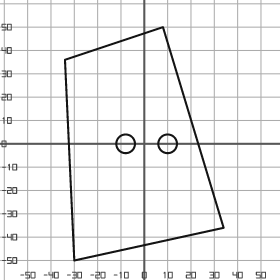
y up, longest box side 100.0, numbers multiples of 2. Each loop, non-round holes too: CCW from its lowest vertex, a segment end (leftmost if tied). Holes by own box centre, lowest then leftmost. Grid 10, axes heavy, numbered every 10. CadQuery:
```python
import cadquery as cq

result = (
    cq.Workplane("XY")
    .moveTo(-30.0, -50.0)
    .lineTo(34.0, -36.0)
    .lineTo(8.0, 50.0)
    .lineTo(-34.0, 36.0)
    .close()
    .moveTo(-8.0, 0.0)
    .circle(4.0)
    .moveTo(10.0, 0.0)
    .circle(4.0)
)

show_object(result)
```